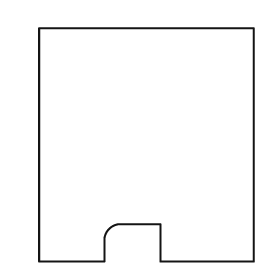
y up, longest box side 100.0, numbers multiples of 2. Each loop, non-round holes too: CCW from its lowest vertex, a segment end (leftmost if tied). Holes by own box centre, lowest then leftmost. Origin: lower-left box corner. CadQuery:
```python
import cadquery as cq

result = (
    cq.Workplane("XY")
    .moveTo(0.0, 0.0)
    .lineTo(28.0, 0.0)
    .lineTo(28.0, 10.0)
    .threePointArc((30.0, 14.0), (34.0, 16.0))
    .lineTo(52.0, 16.0)
    .lineTo(52.0, 0.0)
    .lineTo(92.0, 0.0)
    .lineTo(92.0, 100.0)
    .lineTo(0.0, 100.0)
    .close()
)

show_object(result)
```